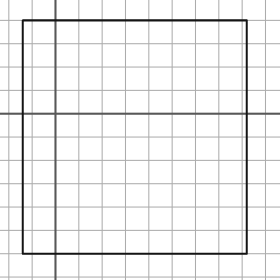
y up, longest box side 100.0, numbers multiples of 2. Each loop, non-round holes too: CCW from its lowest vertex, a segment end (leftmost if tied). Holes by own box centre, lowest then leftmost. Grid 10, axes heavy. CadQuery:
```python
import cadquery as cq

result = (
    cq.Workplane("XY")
    .moveTo(-14.0, -60.0)
    .lineTo(82.0, -60.0)
    .lineTo(82.0, 40.0)
    .lineTo(-14.0, 40.0)
    .close()
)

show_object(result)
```